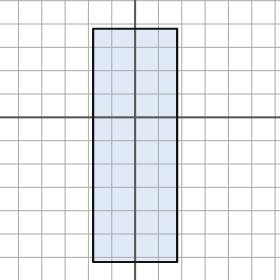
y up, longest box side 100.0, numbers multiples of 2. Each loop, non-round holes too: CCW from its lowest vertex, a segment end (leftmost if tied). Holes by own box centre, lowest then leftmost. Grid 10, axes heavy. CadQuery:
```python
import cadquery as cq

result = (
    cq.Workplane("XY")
    .moveTo(-18.0, -62.0)
    .lineTo(18.0, -62.0)
    .lineTo(18.0, 38.0)
    .lineTo(-18.0, 38.0)
    .close()
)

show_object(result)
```